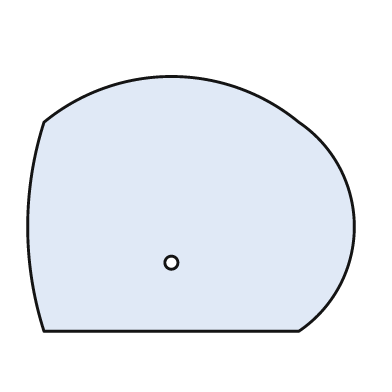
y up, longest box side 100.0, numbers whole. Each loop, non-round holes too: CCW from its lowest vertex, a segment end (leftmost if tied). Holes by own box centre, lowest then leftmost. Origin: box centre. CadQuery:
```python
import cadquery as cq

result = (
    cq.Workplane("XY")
    .moveTo(-45.0, -39.0)
    .lineTo(33.0, -39.0)
    .threePointArc((50.0, -7.0), (33.0, 25.0))
    .threePointArc((-6.0, 39.0), (-45.0, 25.0))
    .threePointArc((-50.0, -7.0), (-45.0, -39.0))
    .close()
    .moveTo(-6.0, -18.0)
    .circle(2.0)
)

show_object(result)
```